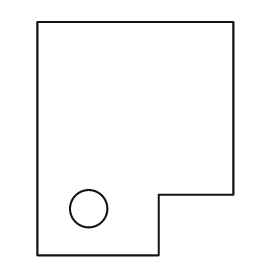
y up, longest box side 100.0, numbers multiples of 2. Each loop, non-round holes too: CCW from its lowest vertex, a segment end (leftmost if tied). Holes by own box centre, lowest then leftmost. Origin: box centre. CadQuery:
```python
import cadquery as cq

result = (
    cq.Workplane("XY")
    .moveTo(-42.0, -50.0)
    .lineTo(10.0, -50.0)
    .lineTo(10.0, -24.0)
    .lineTo(42.0, -24.0)
    .lineTo(42.0, 50.0)
    .lineTo(-42.0, 50.0)
    .close()
    .moveTo(-20.0, -30.0)
    .circle(8.0)
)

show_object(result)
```